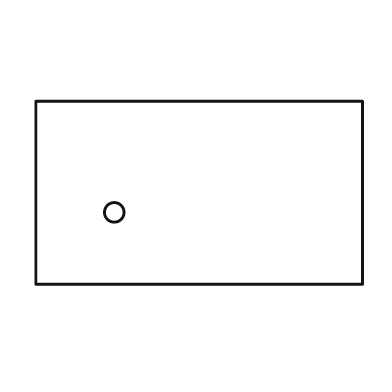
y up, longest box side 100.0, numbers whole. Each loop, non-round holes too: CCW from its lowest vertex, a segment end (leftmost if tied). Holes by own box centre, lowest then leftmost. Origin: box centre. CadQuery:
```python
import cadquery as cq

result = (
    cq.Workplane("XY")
    .moveTo(-50.0, -28.0)
    .lineTo(50.0, -28.0)
    .lineTo(50.0, 28.0)
    .lineTo(-50.0, 28.0)
    .close()
    .moveTo(-26.0, -6.0)
    .circle(3.0)
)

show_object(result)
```